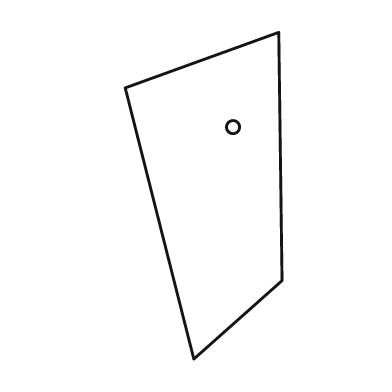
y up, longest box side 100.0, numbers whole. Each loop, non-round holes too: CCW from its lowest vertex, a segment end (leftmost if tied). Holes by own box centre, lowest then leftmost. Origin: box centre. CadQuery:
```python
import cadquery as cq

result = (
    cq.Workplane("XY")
    .moveTo(-3.0, -50.0)
    .lineTo(24.0, -26.0)
    .lineTo(23.0, 50.0)
    .lineTo(-24.0, 33.0)
    .close()
    .moveTo(9.0, 21.0)
    .circle(2.0)
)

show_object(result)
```